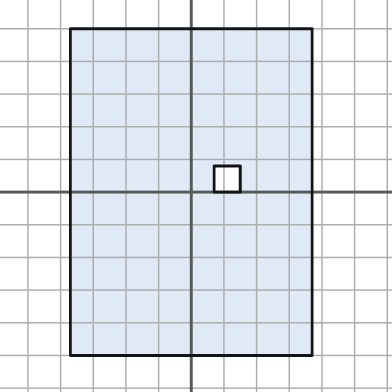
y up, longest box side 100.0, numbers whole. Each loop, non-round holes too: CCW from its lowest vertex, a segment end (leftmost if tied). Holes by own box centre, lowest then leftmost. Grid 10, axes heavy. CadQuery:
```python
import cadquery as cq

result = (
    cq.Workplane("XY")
    .moveTo(-37.0, -50.0)
    .lineTo(37.0, -50.0)
    .lineTo(37.0, 50.0)
    .lineTo(-37.0, 50.0)
    .close()
    .moveTo(7.0, 0.0)
    .lineTo(15.0, 0.0)
    .lineTo(15.0, 8.0)
    .lineTo(7.0, 8.0)
    .close()
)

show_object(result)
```